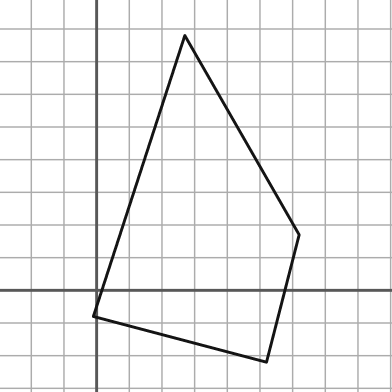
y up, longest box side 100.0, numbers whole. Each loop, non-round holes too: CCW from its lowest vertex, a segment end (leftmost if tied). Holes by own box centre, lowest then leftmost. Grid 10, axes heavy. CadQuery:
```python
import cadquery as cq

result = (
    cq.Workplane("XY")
    .moveTo(52.0, -22.0)
    .lineTo(62.0, 17.0)
    .lineTo(27.0, 78.0)
    .lineTo(-1.0, -8.0)
    .close()
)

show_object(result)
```